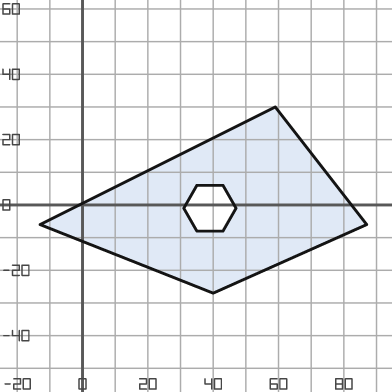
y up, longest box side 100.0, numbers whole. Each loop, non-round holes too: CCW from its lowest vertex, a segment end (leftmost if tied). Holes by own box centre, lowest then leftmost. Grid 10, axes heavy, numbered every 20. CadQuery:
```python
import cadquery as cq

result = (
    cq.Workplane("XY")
    .moveTo(40.0, -27.0)
    .lineTo(87.0, -6.0)
    .lineTo(59.0, 30.0)
    .lineTo(-13.0, -6.0)
    .close()
    .moveTo(35.0, -8.0)
    .lineTo(43.0, -8.0)
    .lineTo(47.0, -1.0)
    .lineTo(43.0, 6.0)
    .lineTo(35.0, 6.0)
    .lineTo(31.0, -1.0)
    .close()
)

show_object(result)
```